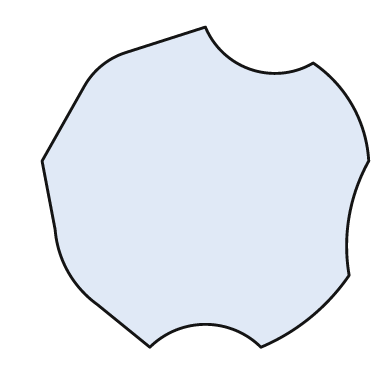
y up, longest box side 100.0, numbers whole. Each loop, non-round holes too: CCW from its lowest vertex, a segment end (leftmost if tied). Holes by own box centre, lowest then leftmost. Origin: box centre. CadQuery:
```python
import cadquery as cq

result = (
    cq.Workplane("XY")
    .moveTo(-17.0, -49.0)
    .threePointArc((0.0, -42.0), (17.0, -49.0))
    .threePointArc((32.0, -40.0), (44.0, -27.0))
    .threePointArc((44.0, -9.0), (50.0, 8.0))
    .threePointArc((45.0, 25.0), (33.0, 38.0))
    .threePointArc((14.0, 36.0), (0.0, 49.0))
    .lineTo(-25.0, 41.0)
    .threePointArc((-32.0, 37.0), (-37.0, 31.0))
    .lineTo(-50.0, 8.0)
    .lineTo(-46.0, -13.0)
    .threePointArc((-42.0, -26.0), (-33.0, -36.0))
    .close()
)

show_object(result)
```